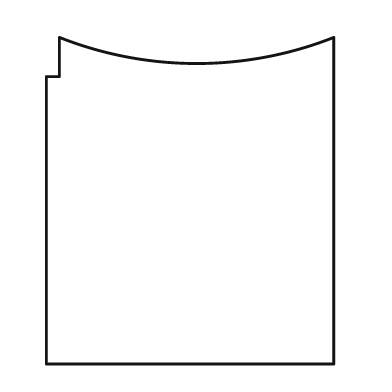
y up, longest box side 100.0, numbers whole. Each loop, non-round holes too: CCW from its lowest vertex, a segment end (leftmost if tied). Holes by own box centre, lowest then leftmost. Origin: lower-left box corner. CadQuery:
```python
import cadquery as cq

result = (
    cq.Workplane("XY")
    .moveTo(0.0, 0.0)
    .lineTo(88.0, 0.0)
    .lineTo(88.0, 100.0)
    .threePointArc((46.0, 92.0), (4.0, 100.0))
    .lineTo(4.0, 88.0)
    .lineTo(0.0, 88.0)
    .close()
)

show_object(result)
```